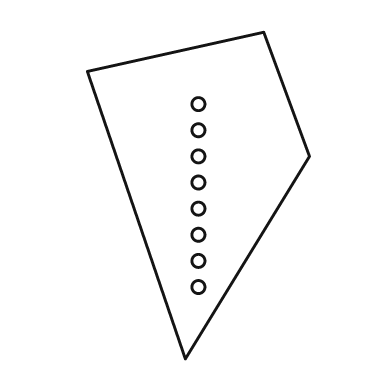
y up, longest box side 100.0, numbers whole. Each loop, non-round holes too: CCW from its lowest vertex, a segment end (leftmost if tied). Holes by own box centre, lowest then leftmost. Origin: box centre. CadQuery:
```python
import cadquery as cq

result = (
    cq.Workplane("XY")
    .moveTo(-4.0, -50.0)
    .lineTo(34.0, 12.0)
    .lineTo(20.0, 50.0)
    .lineTo(-34.0, 38.0)
    .close()
    .moveTo(0.0, -28.0)
    .circle(2.0)
    .moveTo(0.0, -20.0)
    .circle(2.0)
    .moveTo(0.0, -12.0)
    .circle(2.0)
    .moveTo(0.0, -4.0)
    .circle(2.0)
    .moveTo(0.0, 4.0)
    .circle(2.0)
    .moveTo(0.0, 12.0)
    .circle(2.0)
    .moveTo(0.0, 20.0)
    .circle(2.0)
    .moveTo(0.0, 28.0)
    .circle(2.0)
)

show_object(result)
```